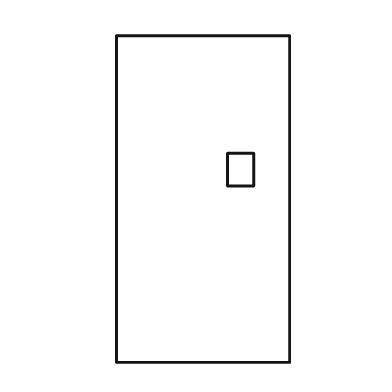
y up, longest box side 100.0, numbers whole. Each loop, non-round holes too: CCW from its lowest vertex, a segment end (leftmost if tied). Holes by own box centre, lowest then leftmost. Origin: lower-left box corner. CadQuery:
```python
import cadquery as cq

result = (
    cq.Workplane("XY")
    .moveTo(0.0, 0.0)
    .lineTo(53.0, 0.0)
    .lineTo(53.0, 100.0)
    .lineTo(0.0, 100.0)
    .close()
    .moveTo(34.0, 54.0)
    .lineTo(42.0, 54.0)
    .lineTo(42.0, 64.0)
    .lineTo(34.0, 64.0)
    .close()
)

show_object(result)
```